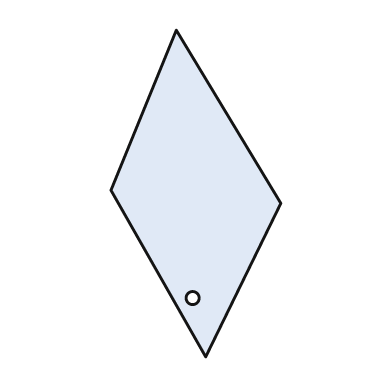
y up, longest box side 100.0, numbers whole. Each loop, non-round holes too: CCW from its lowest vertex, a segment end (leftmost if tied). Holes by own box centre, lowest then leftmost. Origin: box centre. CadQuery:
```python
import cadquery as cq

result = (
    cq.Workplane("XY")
    .moveTo(3.0, -50.0)
    .lineTo(26.0, -3.0)
    .lineTo(-6.0, 50.0)
    .lineTo(-26.0, 1.0)
    .close()
    .moveTo(-1.0, -32.0)
    .circle(2.0)
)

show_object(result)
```